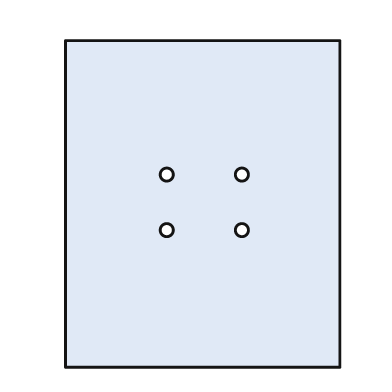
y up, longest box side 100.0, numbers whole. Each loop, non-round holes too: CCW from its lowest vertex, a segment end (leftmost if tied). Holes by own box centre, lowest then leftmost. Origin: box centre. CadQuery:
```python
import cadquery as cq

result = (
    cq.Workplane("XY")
    .moveTo(-42.0, -50.0)
    .lineTo(42.0, -50.0)
    .lineTo(42.0, 50.0)
    .lineTo(-42.0, 50.0)
    .close()
    .moveTo(-11.0, -8.0)
    .circle(2.0)
    .moveTo(12.0, -8.0)
    .circle(2.0)
    .moveTo(-11.0, 9.0)
    .circle(2.0)
    .moveTo(12.0, 9.0)
    .circle(2.0)
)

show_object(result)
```